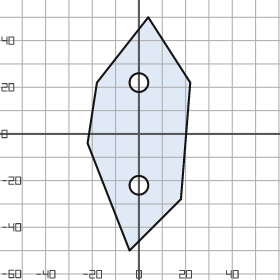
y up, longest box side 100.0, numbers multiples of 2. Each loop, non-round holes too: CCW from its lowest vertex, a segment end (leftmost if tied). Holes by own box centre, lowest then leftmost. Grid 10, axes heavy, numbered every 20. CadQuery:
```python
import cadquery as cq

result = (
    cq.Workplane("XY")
    .moveTo(-4.0, -50.0)
    .lineTo(18.0, -28.0)
    .lineTo(22.0, 22.0)
    .lineTo(4.0, 50.0)
    .lineTo(-18.0, 22.0)
    .lineTo(-22.0, -4.0)
    .close()
    .moveTo(0.0, -22.0)
    .circle(4.0)
    .moveTo(0.0, 22.0)
    .circle(4.0)
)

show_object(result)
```